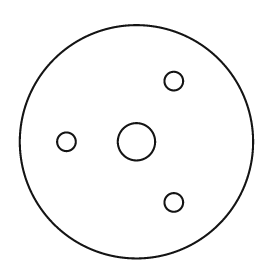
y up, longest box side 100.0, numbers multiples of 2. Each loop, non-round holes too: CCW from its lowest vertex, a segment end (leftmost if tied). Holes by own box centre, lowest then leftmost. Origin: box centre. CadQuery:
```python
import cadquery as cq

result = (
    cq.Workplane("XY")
    .moveTo(0.0, 0.0)
    .circle(50.0)
    .moveTo(16.0, -26.0)
    .circle(4.0)
    .moveTo(-30.0, 0.0)
    .circle(4.0)
    .moveTo(0.0, 0.0)
    .circle(8.0)
    .moveTo(16.0, 26.0)
    .circle(4.0)
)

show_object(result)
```